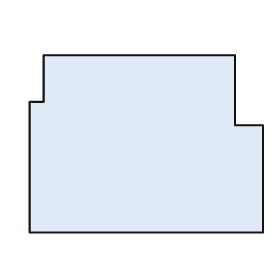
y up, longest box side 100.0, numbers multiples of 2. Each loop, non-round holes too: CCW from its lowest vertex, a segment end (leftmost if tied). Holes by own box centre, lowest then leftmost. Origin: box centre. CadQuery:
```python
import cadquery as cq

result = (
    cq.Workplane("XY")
    .moveTo(-50.0, -38.0)
    .lineTo(50.0, -38.0)
    .lineTo(50.0, 8.0)
    .lineTo(38.0, 8.0)
    .lineTo(38.0, 38.0)
    .lineTo(-44.0, 38.0)
    .lineTo(-44.0, 18.0)
    .lineTo(-50.0, 18.0)
    .close()
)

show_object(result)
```